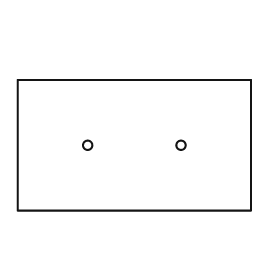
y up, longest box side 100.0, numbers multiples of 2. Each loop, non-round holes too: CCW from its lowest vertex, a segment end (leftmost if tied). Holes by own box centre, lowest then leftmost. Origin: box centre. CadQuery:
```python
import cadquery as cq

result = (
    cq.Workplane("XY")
    .moveTo(-50.0, -28.0)
    .lineTo(50.0, -28.0)
    .lineTo(50.0, 28.0)
    .lineTo(-50.0, 28.0)
    .close()
    .moveTo(-20.0, 0.0)
    .circle(2.0)
    .moveTo(20.0, 0.0)
    .circle(2.0)
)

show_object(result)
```